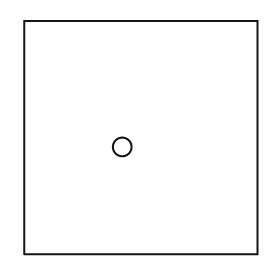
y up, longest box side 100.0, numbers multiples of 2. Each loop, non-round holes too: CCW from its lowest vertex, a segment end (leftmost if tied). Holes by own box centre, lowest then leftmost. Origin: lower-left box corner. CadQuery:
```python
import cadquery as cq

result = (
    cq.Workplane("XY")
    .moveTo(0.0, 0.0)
    .lineTo(100.0, 0.0)
    .lineTo(100.0, 100.0)
    .lineTo(0.0, 100.0)
    .close()
    .moveTo(42.0, 46.0)
    .circle(4.0)
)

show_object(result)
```